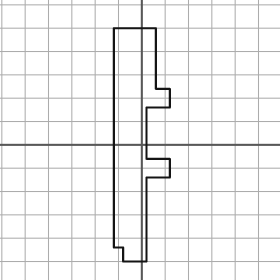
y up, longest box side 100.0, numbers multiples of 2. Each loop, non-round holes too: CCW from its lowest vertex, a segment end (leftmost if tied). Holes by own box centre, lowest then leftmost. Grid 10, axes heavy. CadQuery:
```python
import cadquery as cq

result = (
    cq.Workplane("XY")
    .moveTo(-8.0, -50.0)
    .lineTo(2.0, -50.0)
    .lineTo(2.0, -14.0)
    .lineTo(12.0, -14.0)
    .lineTo(12.0, -6.0)
    .lineTo(2.0, -6.0)
    .lineTo(2.0, 16.0)
    .lineTo(12.0, 16.0)
    .lineTo(12.0, 24.0)
    .lineTo(6.0, 24.0)
    .lineTo(6.0, 50.0)
    .lineTo(-12.0, 50.0)
    .lineTo(-12.0, -44.0)
    .lineTo(-8.0, -44.0)
    .close()
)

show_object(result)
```